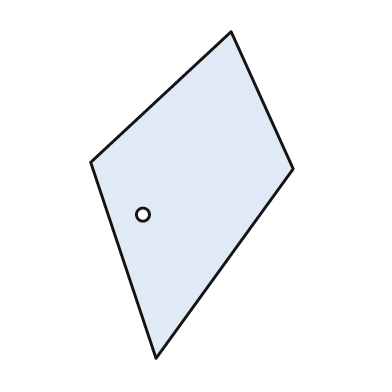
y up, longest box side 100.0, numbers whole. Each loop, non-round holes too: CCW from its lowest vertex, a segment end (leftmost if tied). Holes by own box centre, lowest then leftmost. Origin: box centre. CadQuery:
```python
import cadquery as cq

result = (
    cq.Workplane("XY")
    .moveTo(-11.0, -50.0)
    .lineTo(31.0, 8.0)
    .lineTo(12.0, 50.0)
    .lineTo(-31.0, 10.0)
    .close()
    .moveTo(-15.0, -6.0)
    .circle(2.0)
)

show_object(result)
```